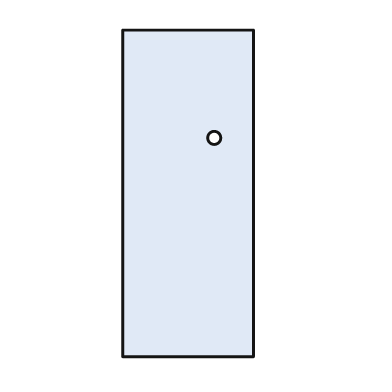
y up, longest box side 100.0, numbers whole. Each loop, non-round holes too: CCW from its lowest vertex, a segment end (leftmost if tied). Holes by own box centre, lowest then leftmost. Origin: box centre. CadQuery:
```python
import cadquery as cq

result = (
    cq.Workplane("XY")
    .moveTo(-20.0, -50.0)
    .lineTo(20.0, -50.0)
    .lineTo(20.0, 50.0)
    .lineTo(-20.0, 50.0)
    .close()
    .moveTo(8.0, 17.0)
    .circle(2.0)
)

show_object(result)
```